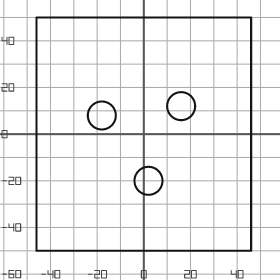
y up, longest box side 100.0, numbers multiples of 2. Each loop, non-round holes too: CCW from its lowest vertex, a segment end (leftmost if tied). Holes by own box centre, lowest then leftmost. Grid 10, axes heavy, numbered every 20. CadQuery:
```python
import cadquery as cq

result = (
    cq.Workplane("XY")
    .moveTo(-46.0, -50.0)
    .lineTo(46.0, -50.0)
    .lineTo(46.0, 50.0)
    .lineTo(-46.0, 50.0)
    .close()
    .moveTo(2.0, -20.0)
    .circle(6.0)
    .moveTo(-18.0, 8.0)
    .circle(6.0)
    .moveTo(16.0, 12.0)
    .circle(6.0)
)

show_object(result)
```